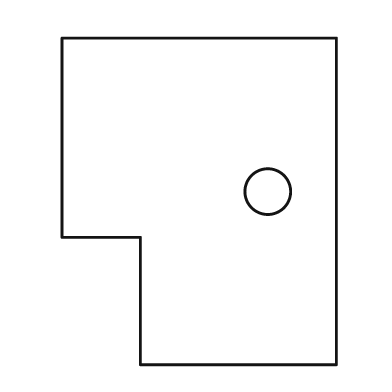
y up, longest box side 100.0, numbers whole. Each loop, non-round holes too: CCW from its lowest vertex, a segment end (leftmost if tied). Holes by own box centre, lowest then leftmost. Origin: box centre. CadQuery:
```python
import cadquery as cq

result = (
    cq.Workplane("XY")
    .moveTo(-18.0, -50.0)
    .lineTo(42.0, -50.0)
    .lineTo(42.0, 50.0)
    .lineTo(-42.0, 50.0)
    .lineTo(-42.0, -11.0)
    .lineTo(-18.0, -11.0)
    .close()
    .moveTo(21.0, 3.0)
    .circle(7.0)
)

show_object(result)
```